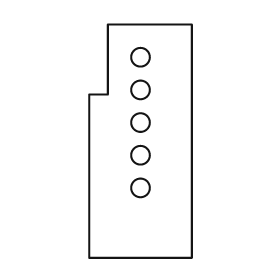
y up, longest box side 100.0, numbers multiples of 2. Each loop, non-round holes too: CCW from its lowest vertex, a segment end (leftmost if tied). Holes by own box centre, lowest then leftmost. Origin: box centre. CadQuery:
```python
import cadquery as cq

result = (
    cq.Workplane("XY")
    .moveTo(-22.0, -50.0)
    .lineTo(22.0, -50.0)
    .lineTo(22.0, 50.0)
    .lineTo(-14.0, 50.0)
    .lineTo(-14.0, 20.0)
    .lineTo(-22.0, 20.0)
    .close()
    .moveTo(0.0, -20.0)
    .circle(4.0)
    .moveTo(0.0, -6.0)
    .circle(4.0)
    .moveTo(0.0, 8.0)
    .circle(4.0)
    .moveTo(0.0, 22.0)
    .circle(4.0)
    .moveTo(0.0, 36.0)
    .circle(4.0)
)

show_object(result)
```